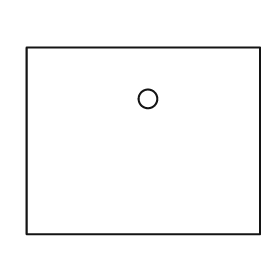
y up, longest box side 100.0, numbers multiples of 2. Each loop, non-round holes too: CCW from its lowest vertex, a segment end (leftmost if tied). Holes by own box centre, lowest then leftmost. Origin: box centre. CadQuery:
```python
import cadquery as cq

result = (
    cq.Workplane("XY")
    .moveTo(-50.0, -40.0)
    .lineTo(50.0, -40.0)
    .lineTo(50.0, 40.0)
    .lineTo(-50.0, 40.0)
    .close()
    .moveTo(2.0, 18.0)
    .circle(4.0)
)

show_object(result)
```